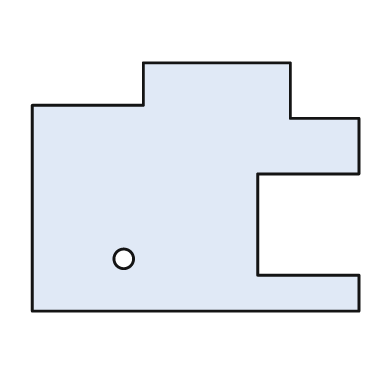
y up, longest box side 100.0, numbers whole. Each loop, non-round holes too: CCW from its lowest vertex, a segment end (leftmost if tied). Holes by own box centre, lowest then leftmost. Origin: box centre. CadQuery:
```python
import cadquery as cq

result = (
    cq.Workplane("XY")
    .moveTo(-50.0, -38.0)
    .lineTo(50.0, -38.0)
    .lineTo(50.0, -27.0)
    .lineTo(19.0, -27.0)
    .lineTo(19.0, 4.0)
    .lineTo(50.0, 4.0)
    .lineTo(50.0, 21.0)
    .lineTo(29.0, 21.0)
    .lineTo(29.0, 38.0)
    .lineTo(-16.0, 38.0)
    .lineTo(-16.0, 25.0)
    .lineTo(-50.0, 25.0)
    .close()
    .moveTo(-22.0, -22.0)
    .circle(3.0)
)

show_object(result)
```